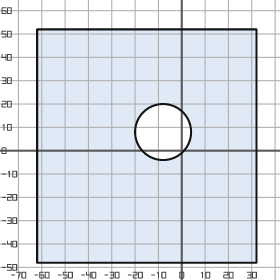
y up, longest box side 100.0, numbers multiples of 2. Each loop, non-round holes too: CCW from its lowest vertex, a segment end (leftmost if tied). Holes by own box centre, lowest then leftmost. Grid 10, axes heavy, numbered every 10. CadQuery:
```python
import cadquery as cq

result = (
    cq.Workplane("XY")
    .moveTo(-62.0, -48.0)
    .lineTo(32.0, -48.0)
    .lineTo(32.0, 52.0)
    .lineTo(-62.0, 52.0)
    .close()
    .moveTo(-8.0, 8.0)
    .circle(12.0)
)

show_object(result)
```